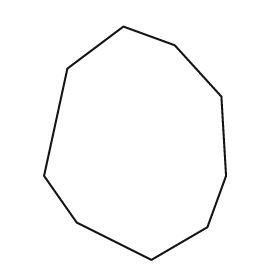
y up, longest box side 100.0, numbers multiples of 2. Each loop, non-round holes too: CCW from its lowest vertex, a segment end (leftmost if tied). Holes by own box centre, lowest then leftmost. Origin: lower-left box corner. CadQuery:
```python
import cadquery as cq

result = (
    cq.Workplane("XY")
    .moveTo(46.0, 0.0)
    .lineTo(70.0, 14.0)
    .lineTo(78.0, 36.0)
    .lineTo(76.0, 70.0)
    .lineTo(56.0, 92.0)
    .lineTo(34.0, 100.0)
    .lineTo(10.0, 82.0)
    .lineTo(0.0, 36.0)
    .lineTo(14.0, 16.0)
    .close()
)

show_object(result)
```